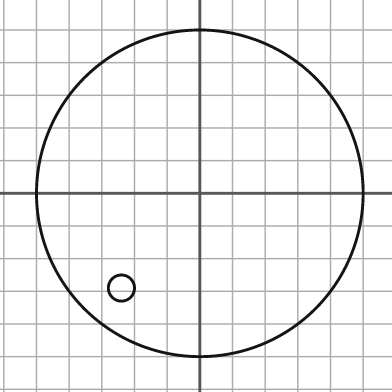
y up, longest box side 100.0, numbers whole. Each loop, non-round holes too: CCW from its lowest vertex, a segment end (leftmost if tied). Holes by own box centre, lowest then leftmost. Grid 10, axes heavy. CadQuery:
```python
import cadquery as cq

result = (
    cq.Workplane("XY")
    .moveTo(0.0, 0.0)
    .circle(50.0)
    .moveTo(-24.0, -29.0)
    .circle(4.0)
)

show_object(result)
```